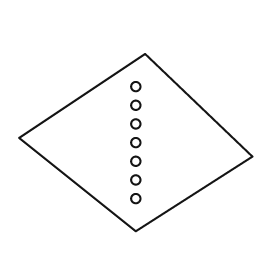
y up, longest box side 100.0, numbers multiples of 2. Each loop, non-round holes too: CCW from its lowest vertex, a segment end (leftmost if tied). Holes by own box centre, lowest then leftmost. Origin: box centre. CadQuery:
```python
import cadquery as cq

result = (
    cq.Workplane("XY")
    .moveTo(0.0, -38.0)
    .lineTo(50.0, -6.0)
    .lineTo(4.0, 38.0)
    .lineTo(-50.0, 2.0)
    .close()
    .moveTo(0.0, -24.0)
    .circle(2.0)
    .moveTo(0.0, -16.0)
    .circle(2.0)
    .moveTo(0.0, -8.0)
    .circle(2.0)
    .moveTo(0.0, 0.0)
    .circle(2.0)
    .moveTo(0.0, 8.0)
    .circle(2.0)
    .moveTo(0.0, 16.0)
    .circle(2.0)
    .moveTo(0.0, 24.0)
    .circle(2.0)
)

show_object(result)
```